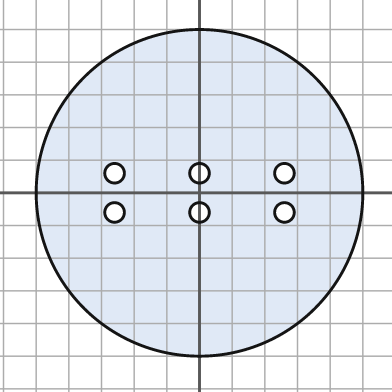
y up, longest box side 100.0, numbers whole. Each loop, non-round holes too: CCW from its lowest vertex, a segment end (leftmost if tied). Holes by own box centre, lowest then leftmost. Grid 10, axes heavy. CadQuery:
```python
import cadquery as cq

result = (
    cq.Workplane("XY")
    .moveTo(0.0, 0.0)
    .circle(50.0)
    .moveTo(-26.0, -6.0)
    .circle(3.0)
    .moveTo(0.0, -6.0)
    .circle(3.0)
    .moveTo(26.0, -6.0)
    .circle(3.0)
    .moveTo(-26.0, 6.0)
    .circle(3.0)
    .moveTo(0.0, 6.0)
    .circle(3.0)
    .moveTo(26.0, 6.0)
    .circle(3.0)
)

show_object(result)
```